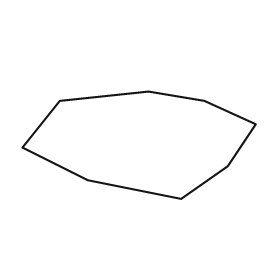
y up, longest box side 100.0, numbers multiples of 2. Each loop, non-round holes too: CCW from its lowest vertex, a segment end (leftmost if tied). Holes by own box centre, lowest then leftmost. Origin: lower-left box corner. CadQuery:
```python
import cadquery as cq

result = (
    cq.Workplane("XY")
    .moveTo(68.0, 0.0)
    .lineTo(88.0, 14.0)
    .lineTo(100.0, 32.0)
    .lineTo(78.0, 42.0)
    .lineTo(54.0, 46.0)
    .lineTo(16.0, 42.0)
    .lineTo(0.0, 22.0)
    .lineTo(28.0, 8.0)
    .close()
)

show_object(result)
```